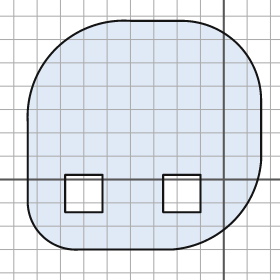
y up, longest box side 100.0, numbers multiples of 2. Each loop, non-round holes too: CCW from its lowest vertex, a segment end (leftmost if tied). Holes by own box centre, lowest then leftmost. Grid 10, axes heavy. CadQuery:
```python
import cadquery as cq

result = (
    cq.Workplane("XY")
    .moveTo(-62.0, -30.0)
    .lineTo(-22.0, -30.0)
    .threePointArc((4.0, -18.0), (16.0, 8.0))
    .lineTo(16.0, 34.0)
    .threePointArc((6.0, 58.0), (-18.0, 68.0))
    .lineTo(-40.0, 68.0)
    .threePointArc((-72.0, 56.0), (-84.0, 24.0))
    .lineTo(-84.0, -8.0)
    .threePointArc((-78.0, -24.0), (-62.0, -30.0))
    .close()
    .moveTo(-68.0, -14.0)
    .lineTo(-52.0, -14.0)
    .lineTo(-52.0, 2.0)
    .lineTo(-68.0, 2.0)
    .close()
    .moveTo(-26.0, -14.0)
    .lineTo(-10.0, -14.0)
    .lineTo(-10.0, 2.0)
    .lineTo(-26.0, 2.0)
    .close()
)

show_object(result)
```